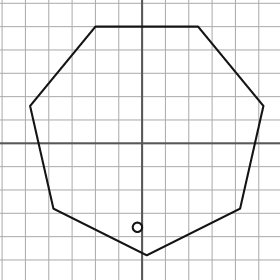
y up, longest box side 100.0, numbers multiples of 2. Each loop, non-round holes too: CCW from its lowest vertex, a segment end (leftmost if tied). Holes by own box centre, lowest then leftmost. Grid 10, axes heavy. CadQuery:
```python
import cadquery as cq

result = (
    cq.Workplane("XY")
    .moveTo(2.0, -48.0)
    .lineTo(42.0, -28.0)
    .lineTo(52.0, 16.0)
    .lineTo(24.0, 50.0)
    .lineTo(-20.0, 50.0)
    .lineTo(-48.0, 16.0)
    .lineTo(-38.0, -28.0)
    .close()
    .moveTo(-2.0, -36.0)
    .circle(2.0)
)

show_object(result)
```